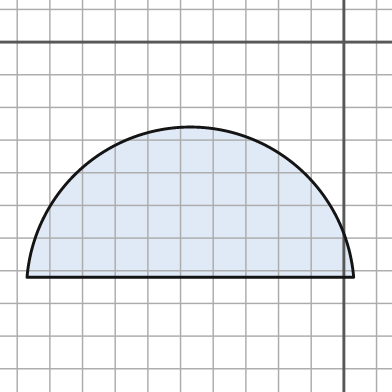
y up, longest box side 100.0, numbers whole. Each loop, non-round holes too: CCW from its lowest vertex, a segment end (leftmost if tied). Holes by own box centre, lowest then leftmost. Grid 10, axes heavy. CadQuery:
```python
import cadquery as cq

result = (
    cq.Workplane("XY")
    .moveTo(-97.0, -72.0)
    .lineTo(3.0, -72.0)
    .threePointArc((-47.0, -26.0), (-97.0, -72.0))
    .close()
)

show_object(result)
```